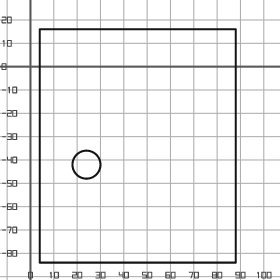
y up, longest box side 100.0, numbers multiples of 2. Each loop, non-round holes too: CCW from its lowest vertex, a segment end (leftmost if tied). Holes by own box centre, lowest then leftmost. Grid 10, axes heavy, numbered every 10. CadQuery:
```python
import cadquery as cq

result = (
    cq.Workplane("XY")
    .moveTo(4.0, -84.0)
    .lineTo(88.0, -84.0)
    .lineTo(88.0, 16.0)
    .lineTo(4.0, 16.0)
    .close()
    .moveTo(24.0, -42.0)
    .circle(6.0)
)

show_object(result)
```